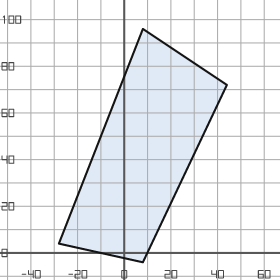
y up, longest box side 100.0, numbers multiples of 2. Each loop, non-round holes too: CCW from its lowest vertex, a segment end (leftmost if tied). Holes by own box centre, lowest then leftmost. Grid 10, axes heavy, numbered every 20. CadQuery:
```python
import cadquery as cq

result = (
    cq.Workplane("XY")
    .moveTo(8.0, -4.0)
    .lineTo(44.0, 72.0)
    .lineTo(8.0, 96.0)
    .lineTo(-28.0, 4.0)
    .close()
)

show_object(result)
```